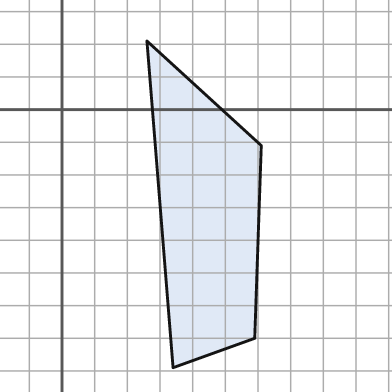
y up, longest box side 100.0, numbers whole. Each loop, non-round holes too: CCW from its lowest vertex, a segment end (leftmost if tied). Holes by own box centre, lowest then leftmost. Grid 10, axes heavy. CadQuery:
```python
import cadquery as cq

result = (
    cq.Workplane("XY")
    .moveTo(34.0, -79.0)
    .lineTo(59.0, -70.0)
    .lineTo(61.0, -11.0)
    .lineTo(26.0, 21.0)
    .close()
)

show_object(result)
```